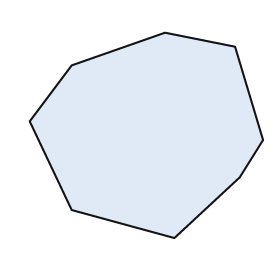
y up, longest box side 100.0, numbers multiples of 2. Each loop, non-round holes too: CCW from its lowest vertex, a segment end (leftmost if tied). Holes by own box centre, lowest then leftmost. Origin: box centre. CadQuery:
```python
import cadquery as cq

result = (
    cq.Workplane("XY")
    .moveTo(12.0, -44.0)
    .lineTo(40.0, -18.0)
    .lineTo(50.0, -2.0)
    .lineTo(38.0, 38.0)
    .lineTo(8.0, 44.0)
    .lineTo(-32.0, 30.0)
    .lineTo(-50.0, 6.0)
    .lineTo(-32.0, -32.0)
    .close()
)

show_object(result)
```